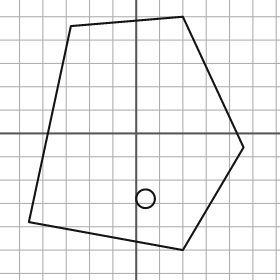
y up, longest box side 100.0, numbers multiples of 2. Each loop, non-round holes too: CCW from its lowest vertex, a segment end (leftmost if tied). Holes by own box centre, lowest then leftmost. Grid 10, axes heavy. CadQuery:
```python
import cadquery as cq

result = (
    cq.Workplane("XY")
    .moveTo(20.0, -50.0)
    .lineTo(46.0, -6.0)
    .lineTo(20.0, 50.0)
    .lineTo(-28.0, 46.0)
    .lineTo(-46.0, -38.0)
    .close()
    .moveTo(4.0, -28.0)
    .circle(4.0)
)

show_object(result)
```